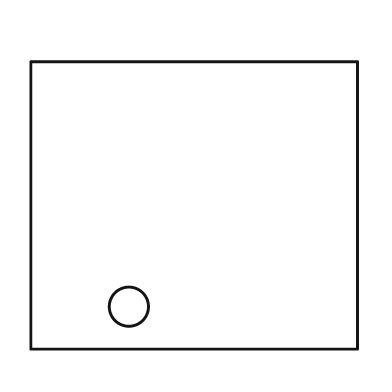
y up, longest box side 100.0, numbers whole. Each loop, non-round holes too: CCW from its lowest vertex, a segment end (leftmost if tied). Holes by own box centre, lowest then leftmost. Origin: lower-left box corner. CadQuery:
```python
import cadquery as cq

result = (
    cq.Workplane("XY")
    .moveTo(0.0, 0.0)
    .lineTo(100.0, 0.0)
    .lineTo(100.0, 88.0)
    .lineTo(0.0, 88.0)
    .close()
    .moveTo(30.0, 13.0)
    .circle(6.0)
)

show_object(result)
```